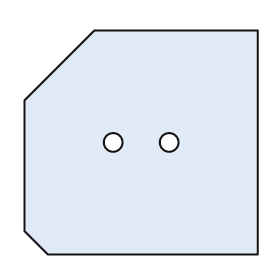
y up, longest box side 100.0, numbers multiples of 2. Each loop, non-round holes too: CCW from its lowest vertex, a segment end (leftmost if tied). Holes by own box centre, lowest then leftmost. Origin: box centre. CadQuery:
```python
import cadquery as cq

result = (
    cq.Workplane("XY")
    .moveTo(-40.0, -48.0)
    .lineTo(50.0, -48.0)
    .lineTo(50.0, 48.0)
    .lineTo(-20.0, 48.0)
    .lineTo(-50.0, 18.0)
    .lineTo(-50.0, -38.0)
    .close()
    .moveTo(-12.0, 0.0)
    .circle(4.0)
    .moveTo(12.0, 0.0)
    .circle(4.0)
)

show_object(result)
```